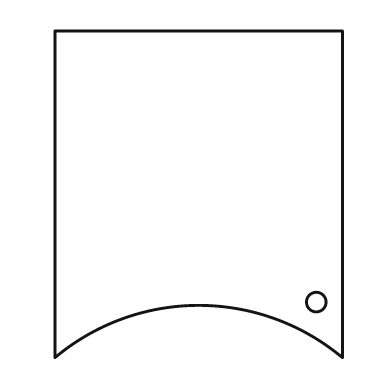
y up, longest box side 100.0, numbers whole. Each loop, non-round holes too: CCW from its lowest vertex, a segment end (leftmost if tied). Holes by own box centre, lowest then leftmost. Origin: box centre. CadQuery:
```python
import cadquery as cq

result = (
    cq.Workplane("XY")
    .moveTo(-44.0, -50.0)
    .threePointArc((0.0, -34.0), (44.0, -50.0))
    .lineTo(44.0, 50.0)
    .lineTo(-44.0, 50.0)
    .close()
    .moveTo(36.0, -33.0)
    .circle(3.0)
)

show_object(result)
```